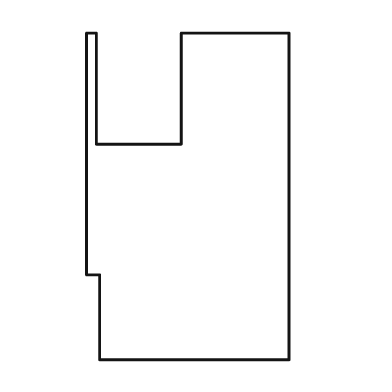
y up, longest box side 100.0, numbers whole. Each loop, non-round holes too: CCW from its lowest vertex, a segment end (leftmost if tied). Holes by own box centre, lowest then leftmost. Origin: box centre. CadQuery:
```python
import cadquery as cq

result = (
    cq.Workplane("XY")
    .moveTo(-27.0, -50.0)
    .lineTo(31.0, -50.0)
    .lineTo(31.0, 50.0)
    .lineTo(-2.0, 50.0)
    .lineTo(-2.0, 16.0)
    .lineTo(-28.0, 16.0)
    .lineTo(-28.0, 50.0)
    .lineTo(-31.0, 50.0)
    .lineTo(-31.0, -24.0)
    .lineTo(-27.0, -24.0)
    .close()
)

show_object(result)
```